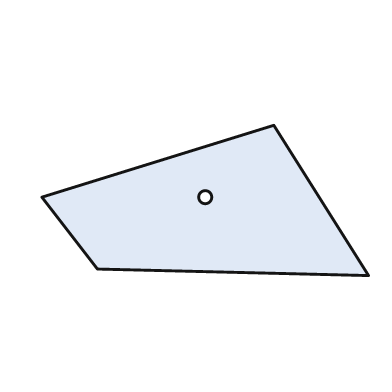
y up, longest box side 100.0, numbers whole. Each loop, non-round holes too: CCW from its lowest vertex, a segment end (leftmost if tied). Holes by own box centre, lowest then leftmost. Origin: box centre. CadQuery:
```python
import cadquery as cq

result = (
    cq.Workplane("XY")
    .moveTo(50.0, -23.0)
    .lineTo(21.0, 23.0)
    .lineTo(-50.0, 1.0)
    .lineTo(-33.0, -21.0)
    .close()
    .moveTo(0.0, 1.0)
    .circle(2.0)
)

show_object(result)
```